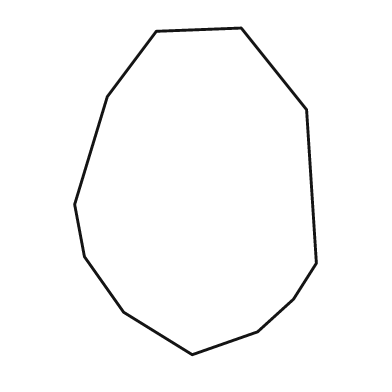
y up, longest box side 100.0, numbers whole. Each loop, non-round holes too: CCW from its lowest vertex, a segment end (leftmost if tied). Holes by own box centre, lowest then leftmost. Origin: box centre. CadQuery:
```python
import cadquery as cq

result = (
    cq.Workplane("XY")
    .moveTo(-1.0, -50.0)
    .lineTo(19.0, -43.0)
    .lineTo(30.0, -33.0)
    .lineTo(37.0, -22.0)
    .lineTo(34.0, 25.0)
    .lineTo(14.0, 50.0)
    .lineTo(-12.0, 49.0)
    .lineTo(-27.0, 29.0)
    .lineTo(-37.0, -4.0)
    .lineTo(-34.0, -20.0)
    .lineTo(-22.0, -37.0)
    .close()
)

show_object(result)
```